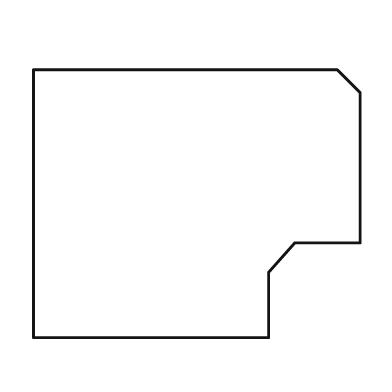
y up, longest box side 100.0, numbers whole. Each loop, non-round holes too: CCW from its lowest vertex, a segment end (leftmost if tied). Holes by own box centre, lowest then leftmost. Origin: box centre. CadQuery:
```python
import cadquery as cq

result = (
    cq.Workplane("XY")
    .moveTo(-50.0, -41.0)
    .lineTo(22.0, -41.0)
    .lineTo(22.0, -21.0)
    .lineTo(30.0, -12.0)
    .lineTo(50.0, -12.0)
    .lineTo(50.0, 34.0)
    .lineTo(43.0, 41.0)
    .lineTo(-50.0, 41.0)
    .close()
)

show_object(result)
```